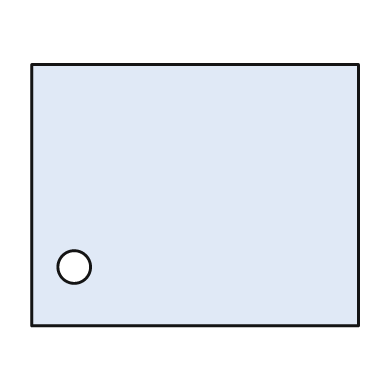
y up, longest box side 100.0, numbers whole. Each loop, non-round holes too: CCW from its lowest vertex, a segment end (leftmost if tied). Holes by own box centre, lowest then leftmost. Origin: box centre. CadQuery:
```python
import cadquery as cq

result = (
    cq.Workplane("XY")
    .moveTo(-50.0, -40.0)
    .lineTo(50.0, -40.0)
    .lineTo(50.0, 40.0)
    .lineTo(-50.0, 40.0)
    .close()
    .moveTo(-37.0, -22.0)
    .circle(5.0)
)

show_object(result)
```